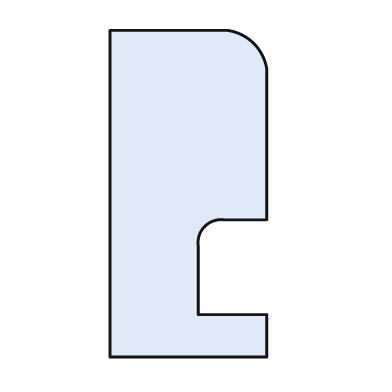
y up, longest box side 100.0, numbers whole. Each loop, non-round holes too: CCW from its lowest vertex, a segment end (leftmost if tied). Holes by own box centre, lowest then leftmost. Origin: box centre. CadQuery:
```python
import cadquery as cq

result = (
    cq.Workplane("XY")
    .moveTo(-24.0, -50.0)
    .lineTo(24.0, -50.0)
    .lineTo(24.0, -37.0)
    .lineTo(3.0, -37.0)
    .lineTo(3.0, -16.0)
    .threePointArc((5.0, -10.0), (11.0, -8.0))
    .lineTo(24.0, -8.0)
    .lineTo(24.0, 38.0)
    .threePointArc((20.0, 46.0), (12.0, 50.0))
    .lineTo(-24.0, 50.0)
    .close()
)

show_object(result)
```